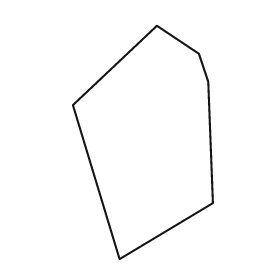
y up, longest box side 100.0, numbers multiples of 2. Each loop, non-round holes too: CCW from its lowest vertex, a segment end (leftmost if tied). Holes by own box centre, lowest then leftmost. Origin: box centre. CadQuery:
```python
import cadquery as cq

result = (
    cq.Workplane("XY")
    .moveTo(-10.0, -50.0)
    .lineTo(30.0, -26.0)
    .lineTo(28.0, 26.0)
    .lineTo(24.0, 38.0)
    .lineTo(6.0, 50.0)
    .lineTo(-30.0, 16.0)
    .close()
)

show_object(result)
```